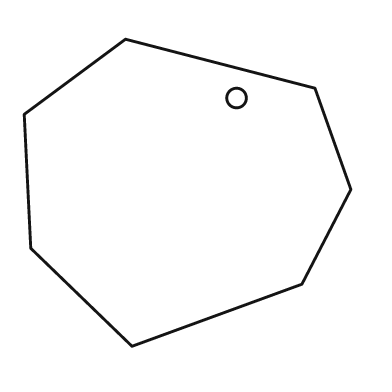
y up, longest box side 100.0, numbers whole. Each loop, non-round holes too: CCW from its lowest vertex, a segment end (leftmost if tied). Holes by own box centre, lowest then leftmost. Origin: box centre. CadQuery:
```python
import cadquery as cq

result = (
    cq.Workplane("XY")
    .moveTo(-17.0, -47.0)
    .lineTo(35.0, -28.0)
    .lineTo(50.0, 1.0)
    .lineTo(39.0, 32.0)
    .lineTo(-19.0, 47.0)
    .lineTo(-50.0, 24.0)
    .lineTo(-48.0, -17.0)
    .close()
    .moveTo(15.0, 29.0)
    .circle(3.0)
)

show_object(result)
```